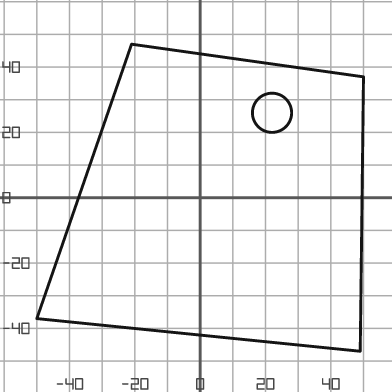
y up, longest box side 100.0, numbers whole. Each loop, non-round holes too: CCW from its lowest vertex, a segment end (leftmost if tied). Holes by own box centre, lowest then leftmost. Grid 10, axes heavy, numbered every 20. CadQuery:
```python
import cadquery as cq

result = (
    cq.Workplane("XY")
    .moveTo(49.0, -47.0)
    .lineTo(50.0, 37.0)
    .lineTo(-21.0, 47.0)
    .lineTo(-50.0, -37.0)
    .close()
    .moveTo(22.0, 26.0)
    .circle(6.0)
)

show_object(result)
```